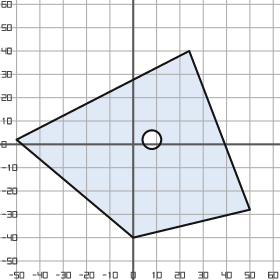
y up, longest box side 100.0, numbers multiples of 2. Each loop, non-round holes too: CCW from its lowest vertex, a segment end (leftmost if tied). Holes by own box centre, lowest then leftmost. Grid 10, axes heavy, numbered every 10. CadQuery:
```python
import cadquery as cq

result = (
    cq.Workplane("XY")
    .moveTo(0.0, -40.0)
    .lineTo(50.0, -28.0)
    .lineTo(24.0, 40.0)
    .lineTo(-50.0, 2.0)
    .close()
    .moveTo(8.0, 2.0)
    .circle(4.0)
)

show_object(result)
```